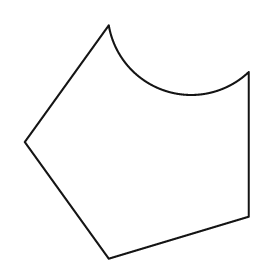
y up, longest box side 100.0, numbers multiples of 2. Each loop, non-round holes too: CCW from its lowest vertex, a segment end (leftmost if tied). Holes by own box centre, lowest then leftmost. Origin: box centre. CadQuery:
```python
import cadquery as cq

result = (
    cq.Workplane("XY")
    .moveTo(-12.0, -50.0)
    .lineTo(48.0, -32.0)
    .lineTo(48.0, 30.0)
    .threePointArc((12.0, 22.0), (-12.0, 50.0))
    .lineTo(-48.0, 0.0)
    .close()
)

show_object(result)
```